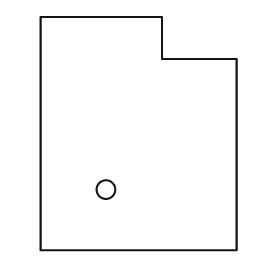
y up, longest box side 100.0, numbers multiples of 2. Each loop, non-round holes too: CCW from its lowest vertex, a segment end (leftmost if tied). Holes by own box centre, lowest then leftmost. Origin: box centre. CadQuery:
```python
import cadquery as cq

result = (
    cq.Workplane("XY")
    .moveTo(-42.0, -50.0)
    .lineTo(42.0, -50.0)
    .lineTo(42.0, 32.0)
    .lineTo(10.0, 32.0)
    .lineTo(10.0, 50.0)
    .lineTo(-42.0, 50.0)
    .close()
    .moveTo(-14.0, -24.0)
    .circle(4.0)
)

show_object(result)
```